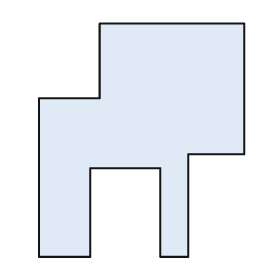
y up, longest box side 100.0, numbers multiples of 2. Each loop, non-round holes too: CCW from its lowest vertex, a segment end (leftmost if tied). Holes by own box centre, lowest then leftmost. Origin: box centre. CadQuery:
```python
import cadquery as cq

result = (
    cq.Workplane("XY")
    .moveTo(-44.0, -50.0)
    .lineTo(-22.0, -50.0)
    .lineTo(-22.0, -12.0)
    .lineTo(8.0, -12.0)
    .lineTo(8.0, -50.0)
    .lineTo(20.0, -50.0)
    .lineTo(20.0, -6.0)
    .lineTo(44.0, -6.0)
    .lineTo(44.0, 50.0)
    .lineTo(-18.0, 50.0)
    .lineTo(-18.0, 18.0)
    .lineTo(-44.0, 18.0)
    .close()
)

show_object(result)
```